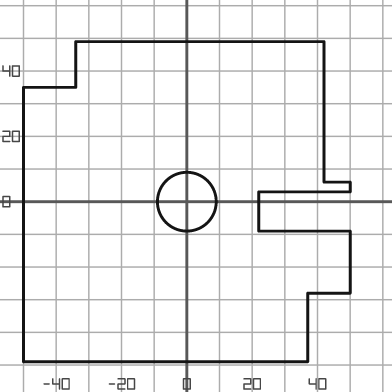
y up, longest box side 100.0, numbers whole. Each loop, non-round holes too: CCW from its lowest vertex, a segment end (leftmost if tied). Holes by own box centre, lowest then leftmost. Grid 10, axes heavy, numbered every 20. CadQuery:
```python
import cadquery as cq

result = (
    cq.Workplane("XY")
    .moveTo(-50.0, -49.0)
    .lineTo(37.0, -49.0)
    .lineTo(37.0, -28.0)
    .lineTo(50.0, -28.0)
    .lineTo(50.0, -9.0)
    .lineTo(22.0, -9.0)
    .lineTo(22.0, 3.0)
    .lineTo(50.0, 3.0)
    .lineTo(50.0, 6.0)
    .lineTo(42.0, 6.0)
    .lineTo(42.0, 49.0)
    .lineTo(-34.0, 49.0)
    .lineTo(-34.0, 35.0)
    .lineTo(-50.0, 35.0)
    .close()
    .moveTo(0.0, 0.0)
    .circle(9.0)
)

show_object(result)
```